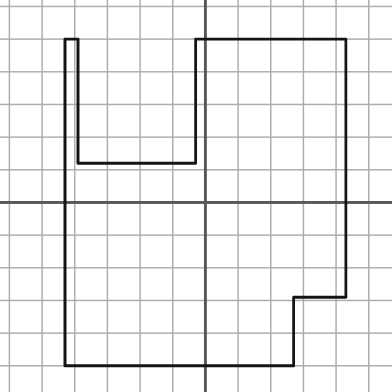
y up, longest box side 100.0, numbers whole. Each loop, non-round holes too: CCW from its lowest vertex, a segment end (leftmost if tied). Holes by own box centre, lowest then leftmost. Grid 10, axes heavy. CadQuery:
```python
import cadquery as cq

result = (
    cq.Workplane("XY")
    .moveTo(-43.0, -50.0)
    .lineTo(27.0, -50.0)
    .lineTo(27.0, -29.0)
    .lineTo(43.0, -29.0)
    .lineTo(43.0, 50.0)
    .lineTo(-3.0, 50.0)
    .lineTo(-3.0, 12.0)
    .lineTo(-39.0, 12.0)
    .lineTo(-39.0, 50.0)
    .lineTo(-43.0, 50.0)
    .close()
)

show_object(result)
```